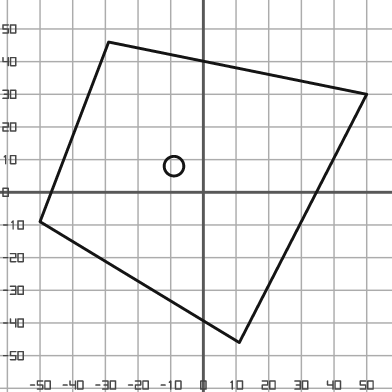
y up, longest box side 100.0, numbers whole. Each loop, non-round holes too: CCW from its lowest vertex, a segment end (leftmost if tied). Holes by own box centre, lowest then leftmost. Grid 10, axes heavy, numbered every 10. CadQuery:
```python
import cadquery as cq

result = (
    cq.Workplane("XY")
    .moveTo(11.0, -46.0)
    .lineTo(50.0, 30.0)
    .lineTo(-29.0, 46.0)
    .lineTo(-50.0, -9.0)
    .close()
    .moveTo(-9.0, 8.0)
    .circle(3.0)
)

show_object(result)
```